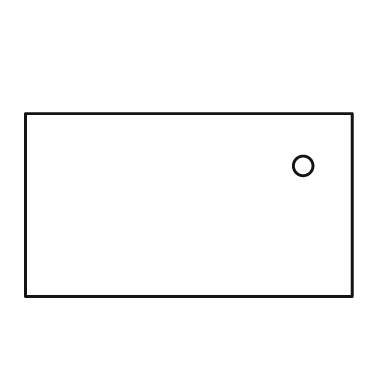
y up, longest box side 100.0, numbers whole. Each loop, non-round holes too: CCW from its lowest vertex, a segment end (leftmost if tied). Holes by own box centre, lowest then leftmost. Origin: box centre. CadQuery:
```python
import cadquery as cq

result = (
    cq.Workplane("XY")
    .moveTo(-50.0, -28.0)
    .lineTo(50.0, -28.0)
    .lineTo(50.0, 28.0)
    .lineTo(-50.0, 28.0)
    .close()
    .moveTo(35.0, 12.0)
    .circle(3.0)
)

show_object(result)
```